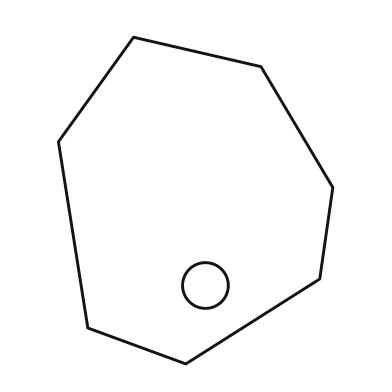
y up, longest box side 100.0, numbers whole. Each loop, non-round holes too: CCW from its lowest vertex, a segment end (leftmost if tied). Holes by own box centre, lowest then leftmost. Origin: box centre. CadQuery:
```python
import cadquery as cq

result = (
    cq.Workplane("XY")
    .moveTo(-3.0, -50.0)
    .lineTo(38.0, -24.0)
    .lineTo(42.0, 4.0)
    .lineTo(20.0, 41.0)
    .lineTo(-19.0, 50.0)
    .lineTo(-42.0, 18.0)
    .lineTo(-33.0, -39.0)
    .close()
    .moveTo(3.0, -26.0)
    .circle(7.0)
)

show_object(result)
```